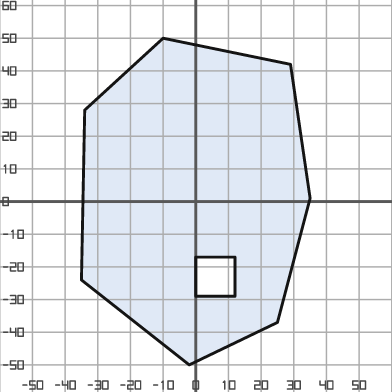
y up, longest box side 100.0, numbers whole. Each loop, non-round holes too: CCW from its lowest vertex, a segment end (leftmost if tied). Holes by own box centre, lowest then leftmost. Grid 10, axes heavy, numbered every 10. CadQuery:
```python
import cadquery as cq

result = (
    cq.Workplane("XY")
    .moveTo(-2.0, -50.0)
    .lineTo(25.0, -37.0)
    .lineTo(35.0, 1.0)
    .lineTo(29.0, 42.0)
    .lineTo(-10.0, 50.0)
    .lineTo(-34.0, 28.0)
    .lineTo(-35.0, -24.0)
    .close()
    .moveTo(0.0, -29.0)
    .lineTo(12.0, -29.0)
    .lineTo(12.0, -17.0)
    .lineTo(0.0, -17.0)
    .close()
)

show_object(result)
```